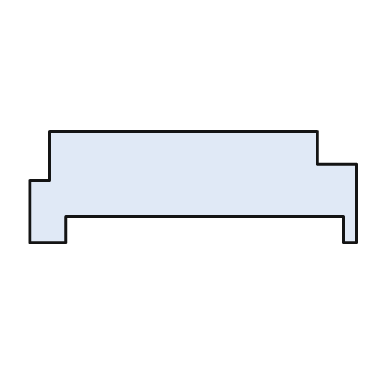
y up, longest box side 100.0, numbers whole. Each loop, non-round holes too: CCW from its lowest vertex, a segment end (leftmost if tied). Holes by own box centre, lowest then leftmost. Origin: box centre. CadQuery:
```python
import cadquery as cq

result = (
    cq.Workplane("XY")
    .moveTo(-50.0, -17.0)
    .lineTo(-39.0, -17.0)
    .lineTo(-39.0, -9.0)
    .lineTo(46.0, -9.0)
    .lineTo(46.0, -17.0)
    .lineTo(50.0, -17.0)
    .lineTo(50.0, 7.0)
    .lineTo(38.0, 7.0)
    .lineTo(38.0, 17.0)
    .lineTo(-44.0, 17.0)
    .lineTo(-44.0, 2.0)
    .lineTo(-50.0, 2.0)
    .close()
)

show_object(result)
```